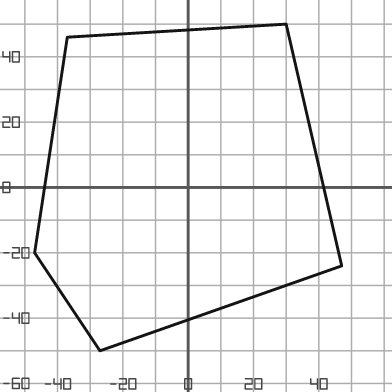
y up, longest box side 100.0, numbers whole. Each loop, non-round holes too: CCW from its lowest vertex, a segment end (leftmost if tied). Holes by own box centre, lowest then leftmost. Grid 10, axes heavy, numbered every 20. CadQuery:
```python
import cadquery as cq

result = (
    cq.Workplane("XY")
    .moveTo(-27.0, -50.0)
    .lineTo(47.0, -24.0)
    .lineTo(30.0, 50.0)
    .lineTo(-37.0, 46.0)
    .lineTo(-47.0, -20.0)
    .close()
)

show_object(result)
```